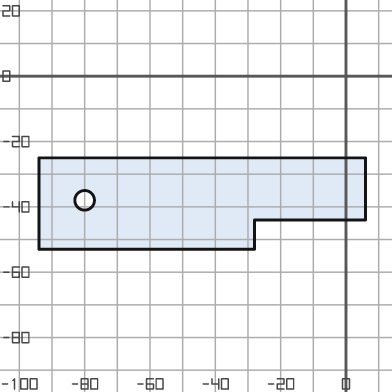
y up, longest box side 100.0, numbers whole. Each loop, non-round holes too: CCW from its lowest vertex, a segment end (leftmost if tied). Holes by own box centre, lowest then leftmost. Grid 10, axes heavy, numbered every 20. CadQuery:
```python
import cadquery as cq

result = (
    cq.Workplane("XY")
    .moveTo(-94.0, -53.0)
    .lineTo(-28.0, -53.0)
    .lineTo(-28.0, -44.0)
    .lineTo(6.0, -44.0)
    .lineTo(6.0, -25.0)
    .lineTo(-94.0, -25.0)
    .close()
    .moveTo(-80.0, -38.0)
    .circle(3.0)
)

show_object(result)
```